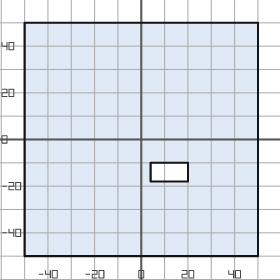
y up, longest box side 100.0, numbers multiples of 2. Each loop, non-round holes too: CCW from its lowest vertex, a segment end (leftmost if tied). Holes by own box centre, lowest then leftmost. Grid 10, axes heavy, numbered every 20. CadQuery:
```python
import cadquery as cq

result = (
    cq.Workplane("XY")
    .moveTo(-50.0, -50.0)
    .lineTo(50.0, -50.0)
    .lineTo(50.0, 50.0)
    .lineTo(-50.0, 50.0)
    .close()
    .moveTo(4.0, -18.0)
    .lineTo(20.0, -18.0)
    .lineTo(20.0, -10.0)
    .lineTo(4.0, -10.0)
    .close()
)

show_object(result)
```